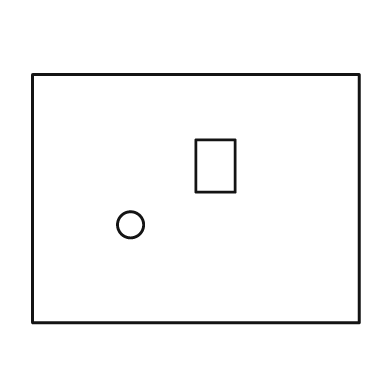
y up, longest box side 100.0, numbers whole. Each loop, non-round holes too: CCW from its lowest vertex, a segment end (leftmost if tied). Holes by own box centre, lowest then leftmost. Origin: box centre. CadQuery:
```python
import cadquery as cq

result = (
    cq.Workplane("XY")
    .moveTo(-50.0, -38.0)
    .lineTo(50.0, -38.0)
    .lineTo(50.0, 38.0)
    .lineTo(-50.0, 38.0)
    .close()
    .moveTo(-20.0, -8.0)
    .circle(4.0)
    .moveTo(0.0, 2.0)
    .lineTo(12.0, 2.0)
    .lineTo(12.0, 18.0)
    .lineTo(0.0, 18.0)
    .close()
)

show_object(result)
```